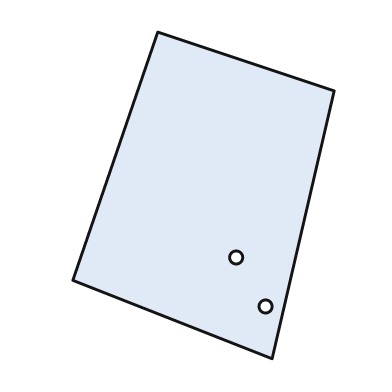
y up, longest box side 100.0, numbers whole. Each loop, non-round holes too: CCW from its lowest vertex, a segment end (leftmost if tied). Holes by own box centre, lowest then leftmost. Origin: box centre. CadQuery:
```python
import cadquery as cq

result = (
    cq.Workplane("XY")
    .moveTo(21.0, -50.0)
    .lineTo(40.0, 32.0)
    .lineTo(-14.0, 50.0)
    .lineTo(-40.0, -26.0)
    .close()
    .moveTo(19.0, -34.0)
    .circle(2.0)
    .moveTo(10.0, -19.0)
    .circle(2.0)
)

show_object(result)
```